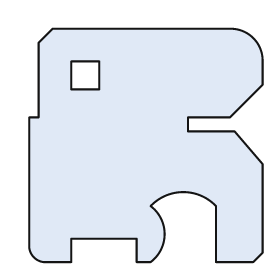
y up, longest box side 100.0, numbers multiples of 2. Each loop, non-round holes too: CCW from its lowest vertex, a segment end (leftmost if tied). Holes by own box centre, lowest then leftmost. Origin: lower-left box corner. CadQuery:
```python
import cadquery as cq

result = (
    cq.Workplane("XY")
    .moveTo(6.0, 0.0)
    .lineTo(18.0, 0.0)
    .lineTo(18.0, 10.0)
    .lineTo(46.0, 10.0)
    .lineTo(46.0, 0.0)
    .lineTo(52.0, 0.0)
    .threePointArc((58.0, 12.0), (52.0, 24.0))
    .threePointArc((66.0, 30.0), (80.0, 24.0))
    .lineTo(80.0, 0.0)
    .lineTo(96.0, 0.0)
    .lineTo(100.0, 4.0)
    .lineTo(100.0, 42.0)
    .lineTo(88.0, 56.0)
    .lineTo(68.0, 56.0)
    .lineTo(68.0, 62.0)
    .lineTo(86.0, 62.0)
    .lineTo(100.0, 76.0)
    .lineTo(100.0, 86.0)
    .threePointArc((96.0, 96.0), (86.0, 100.0))
    .lineTo(10.0, 100.0)
    .lineTo(4.0, 94.0)
    .lineTo(4.0, 62.0)
    .lineTo(0.0, 62.0)
    .lineTo(0.0, 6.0)
    .threePointArc((2.0, 2.0), (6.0, 0.0))
    .close()
    .moveTo(18.0, 74.0)
    .lineTo(30.0, 74.0)
    .lineTo(30.0, 86.0)
    .lineTo(18.0, 86.0)
    .close()
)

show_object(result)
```